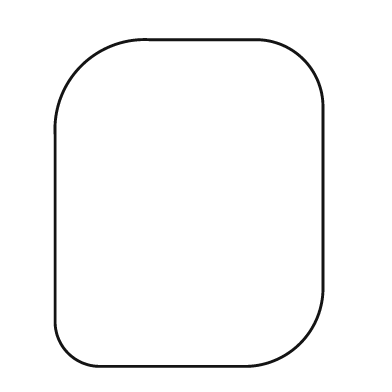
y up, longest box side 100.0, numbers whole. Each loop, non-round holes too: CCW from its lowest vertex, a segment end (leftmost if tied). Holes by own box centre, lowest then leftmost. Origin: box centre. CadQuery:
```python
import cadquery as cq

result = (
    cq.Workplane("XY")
    .moveTo(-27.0, -50.0)
    .lineTo(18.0, -50.0)
    .threePointArc((34.0, -43.0), (41.0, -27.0))
    .lineTo(41.0, 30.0)
    .threePointArc((35.0, 44.0), (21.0, 50.0))
    .lineTo(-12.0, 50.0)
    .threePointArc((-33.0, 42.0), (-41.0, 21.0))
    .lineTo(-41.0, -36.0)
    .threePointArc((-37.0, -46.0), (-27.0, -50.0))
    .close()
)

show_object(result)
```